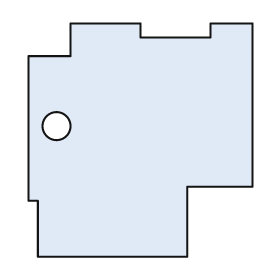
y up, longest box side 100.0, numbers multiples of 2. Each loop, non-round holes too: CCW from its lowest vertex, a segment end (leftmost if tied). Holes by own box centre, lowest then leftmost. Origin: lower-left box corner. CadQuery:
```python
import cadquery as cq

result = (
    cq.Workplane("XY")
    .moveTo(4.0, 0.0)
    .lineTo(68.0, 0.0)
    .lineTo(68.0, 30.0)
    .lineTo(96.0, 30.0)
    .lineTo(96.0, 100.0)
    .lineTo(78.0, 100.0)
    .lineTo(78.0, 94.0)
    .lineTo(48.0, 94.0)
    .lineTo(48.0, 100.0)
    .lineTo(18.0, 100.0)
    .lineTo(18.0, 86.0)
    .lineTo(0.0, 86.0)
    .lineTo(0.0, 24.0)
    .lineTo(4.0, 24.0)
    .close()
    .moveTo(12.0, 56.0)
    .circle(6.0)
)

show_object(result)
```